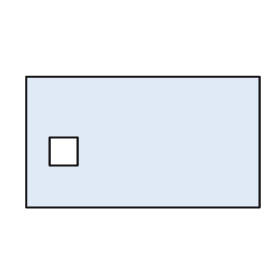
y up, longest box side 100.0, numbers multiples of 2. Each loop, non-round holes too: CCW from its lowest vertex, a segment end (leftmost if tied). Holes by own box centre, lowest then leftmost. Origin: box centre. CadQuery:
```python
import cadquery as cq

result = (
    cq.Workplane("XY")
    .moveTo(-50.0, -28.0)
    .lineTo(50.0, -28.0)
    .lineTo(50.0, 28.0)
    .lineTo(-50.0, 28.0)
    .close()
    .moveTo(-40.0, -10.0)
    .lineTo(-28.0, -10.0)
    .lineTo(-28.0, 2.0)
    .lineTo(-40.0, 2.0)
    .close()
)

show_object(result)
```